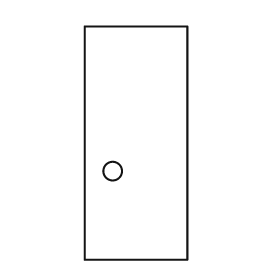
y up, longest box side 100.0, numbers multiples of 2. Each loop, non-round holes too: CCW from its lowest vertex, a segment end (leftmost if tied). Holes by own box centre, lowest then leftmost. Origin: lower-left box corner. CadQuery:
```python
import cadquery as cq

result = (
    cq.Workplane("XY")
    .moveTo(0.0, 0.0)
    .lineTo(44.0, 0.0)
    .lineTo(44.0, 100.0)
    .lineTo(0.0, 100.0)
    .close()
    .moveTo(12.0, 38.0)
    .circle(4.0)
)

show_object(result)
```